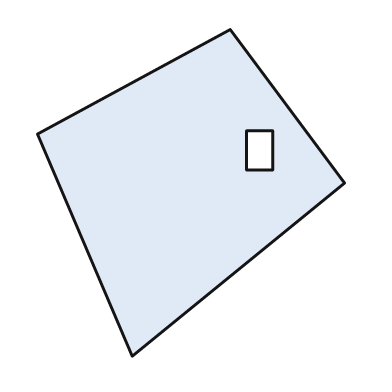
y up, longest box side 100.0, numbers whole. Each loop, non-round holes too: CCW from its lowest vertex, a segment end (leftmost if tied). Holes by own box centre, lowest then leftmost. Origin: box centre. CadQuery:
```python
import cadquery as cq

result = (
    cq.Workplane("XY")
    .moveTo(-18.0, -50.0)
    .lineTo(47.0, 3.0)
    .lineTo(12.0, 50.0)
    .lineTo(-47.0, 18.0)
    .close()
    .moveTo(17.0, 7.0)
    .lineTo(25.0, 7.0)
    .lineTo(25.0, 19.0)
    .lineTo(17.0, 19.0)
    .close()
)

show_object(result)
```